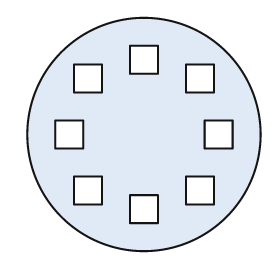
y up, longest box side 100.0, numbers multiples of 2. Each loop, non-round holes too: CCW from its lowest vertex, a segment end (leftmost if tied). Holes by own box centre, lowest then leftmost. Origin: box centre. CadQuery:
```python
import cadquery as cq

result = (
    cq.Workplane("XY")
    .moveTo(0.0, 0.0)
    .circle(50.0)
    .moveTo(-6.0, -38.0)
    .lineTo(6.0, -38.0)
    .lineTo(6.0, -26.0)
    .lineTo(-6.0, -26.0)
    .close()
    .moveTo(-30.0, -30.0)
    .lineTo(-18.0, -30.0)
    .lineTo(-18.0, -18.0)
    .lineTo(-30.0, -18.0)
    .close()
    .moveTo(18.0, -30.0)
    .lineTo(30.0, -30.0)
    .lineTo(30.0, -18.0)
    .lineTo(18.0, -18.0)
    .close()
    .moveTo(-38.0, -6.0)
    .lineTo(-26.0, -6.0)
    .lineTo(-26.0, 6.0)
    .lineTo(-38.0, 6.0)
    .close()
    .moveTo(26.0, -6.0)
    .lineTo(38.0, -6.0)
    .lineTo(38.0, 6.0)
    .lineTo(26.0, 6.0)
    .close()
    .moveTo(-30.0, 18.0)
    .lineTo(-18.0, 18.0)
    .lineTo(-18.0, 30.0)
    .lineTo(-30.0, 30.0)
    .close()
    .moveTo(18.0, 18.0)
    .lineTo(30.0, 18.0)
    .lineTo(30.0, 30.0)
    .lineTo(18.0, 30.0)
    .close()
    .moveTo(-6.0, 26.0)
    .lineTo(6.0, 26.0)
    .lineTo(6.0, 38.0)
    .lineTo(-6.0, 38.0)
    .close()
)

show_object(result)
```